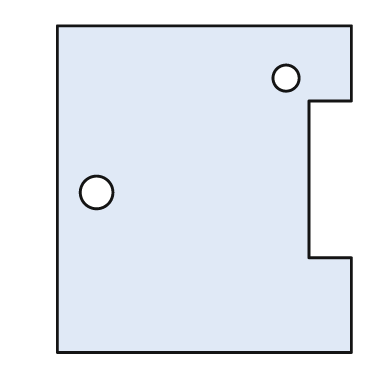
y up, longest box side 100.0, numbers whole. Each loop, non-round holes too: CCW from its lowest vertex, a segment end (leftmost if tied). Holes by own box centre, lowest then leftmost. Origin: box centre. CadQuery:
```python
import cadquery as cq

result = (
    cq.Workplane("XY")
    .moveTo(-45.0, -50.0)
    .lineTo(45.0, -50.0)
    .lineTo(45.0, -21.0)
    .lineTo(32.0, -21.0)
    .lineTo(32.0, 27.0)
    .lineTo(45.0, 27.0)
    .lineTo(45.0, 50.0)
    .lineTo(-45.0, 50.0)
    .close()
    .moveTo(-33.0, -1.0)
    .circle(5.0)
    .moveTo(25.0, 34.0)
    .circle(4.0)
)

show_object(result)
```